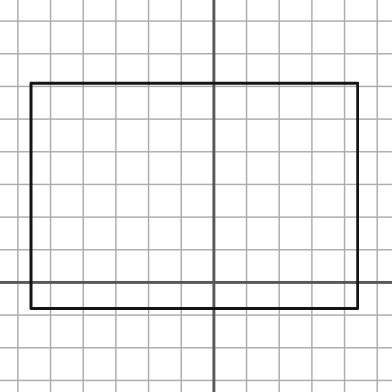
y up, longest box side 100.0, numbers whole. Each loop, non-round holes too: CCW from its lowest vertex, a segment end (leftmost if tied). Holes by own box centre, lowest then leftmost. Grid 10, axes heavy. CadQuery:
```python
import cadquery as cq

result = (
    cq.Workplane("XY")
    .moveTo(-56.0, -8.0)
    .lineTo(44.0, -8.0)
    .lineTo(44.0, 61.0)
    .lineTo(-56.0, 61.0)
    .close()
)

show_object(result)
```